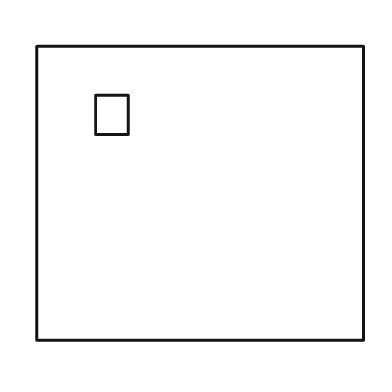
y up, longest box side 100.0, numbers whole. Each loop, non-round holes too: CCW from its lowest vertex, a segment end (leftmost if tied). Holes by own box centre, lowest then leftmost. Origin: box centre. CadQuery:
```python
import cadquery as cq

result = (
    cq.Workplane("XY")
    .moveTo(-50.0, -45.0)
    .lineTo(50.0, -45.0)
    .lineTo(50.0, 45.0)
    .lineTo(-50.0, 45.0)
    .close()
    .moveTo(-32.0, 18.0)
    .lineTo(-22.0, 18.0)
    .lineTo(-22.0, 30.0)
    .lineTo(-32.0, 30.0)
    .close()
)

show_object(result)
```